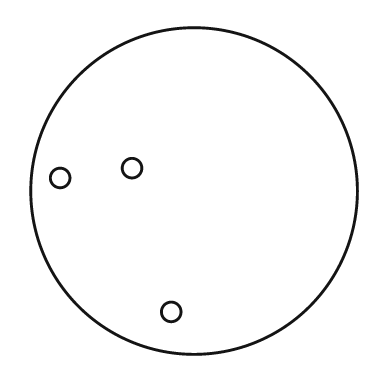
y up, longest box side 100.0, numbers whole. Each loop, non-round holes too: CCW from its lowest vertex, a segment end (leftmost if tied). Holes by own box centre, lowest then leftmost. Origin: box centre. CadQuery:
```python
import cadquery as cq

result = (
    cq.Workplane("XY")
    .moveTo(0.0, 0.0)
    .circle(50.0)
    .moveTo(-7.0, -37.0)
    .circle(3.0)
    .moveTo(-41.0, 4.0)
    .circle(3.0)
    .moveTo(-19.0, 7.0)
    .circle(3.0)
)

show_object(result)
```